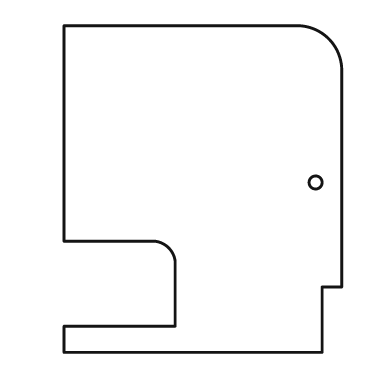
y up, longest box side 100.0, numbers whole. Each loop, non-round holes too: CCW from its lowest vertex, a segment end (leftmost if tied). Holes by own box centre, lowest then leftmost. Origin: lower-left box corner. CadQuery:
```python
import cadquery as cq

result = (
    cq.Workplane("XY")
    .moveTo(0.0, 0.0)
    .lineTo(79.0, 0.0)
    .lineTo(79.0, 20.0)
    .lineTo(85.0, 20.0)
    .lineTo(85.0, 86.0)
    .threePointArc((81.0, 96.0), (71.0, 100.0))
    .lineTo(0.0, 100.0)
    .lineTo(0.0, 34.0)
    .lineTo(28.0, 34.0)
    .threePointArc((32.0, 32.0), (34.0, 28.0))
    .lineTo(34.0, 8.0)
    .lineTo(0.0, 8.0)
    .close()
    .moveTo(77.0, 52.0)
    .circle(2.0)
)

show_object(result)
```